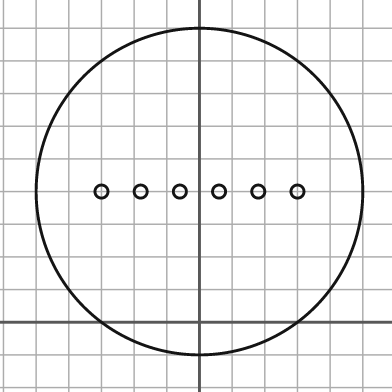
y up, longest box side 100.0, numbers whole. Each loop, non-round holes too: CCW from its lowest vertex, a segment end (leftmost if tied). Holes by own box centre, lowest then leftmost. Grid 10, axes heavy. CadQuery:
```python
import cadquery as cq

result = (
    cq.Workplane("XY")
    .moveTo(0.0, 40.0)
    .circle(50.0)
    .moveTo(-30.0, 40.0)
    .circle(2.0)
    .moveTo(-18.0, 40.0)
    .circle(2.0)
    .moveTo(-6.0, 40.0)
    .circle(2.0)
    .moveTo(6.0, 40.0)
    .circle(2.0)
    .moveTo(18.0, 40.0)
    .circle(2.0)
    .moveTo(30.0, 40.0)
    .circle(2.0)
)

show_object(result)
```